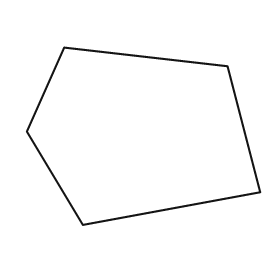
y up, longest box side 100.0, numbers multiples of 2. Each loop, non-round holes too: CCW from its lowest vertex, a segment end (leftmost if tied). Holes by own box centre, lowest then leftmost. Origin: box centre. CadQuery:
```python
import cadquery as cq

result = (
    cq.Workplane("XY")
    .moveTo(-26.0, -38.0)
    .lineTo(50.0, -24.0)
    .lineTo(36.0, 30.0)
    .lineTo(-34.0, 38.0)
    .lineTo(-50.0, 2.0)
    .close()
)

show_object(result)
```